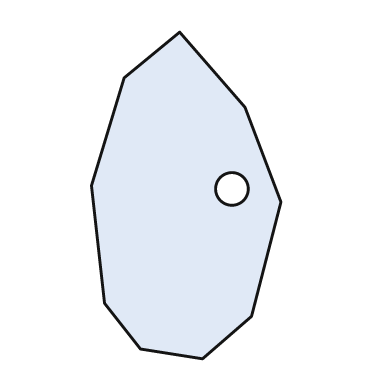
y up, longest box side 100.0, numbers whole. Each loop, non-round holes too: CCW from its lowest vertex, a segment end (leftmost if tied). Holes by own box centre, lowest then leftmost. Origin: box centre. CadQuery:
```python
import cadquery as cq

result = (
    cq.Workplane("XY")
    .moveTo(5.0, -50.0)
    .lineTo(20.0, -37.0)
    .lineTo(29.0, -2.0)
    .lineTo(18.0, 27.0)
    .lineTo(-2.0, 50.0)
    .lineTo(-19.0, 36.0)
    .lineTo(-29.0, 3.0)
    .lineTo(-25.0, -33.0)
    .lineTo(-14.0, -47.0)
    .close()
    .moveTo(14.0, 2.0)
    .circle(5.0)
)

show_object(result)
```